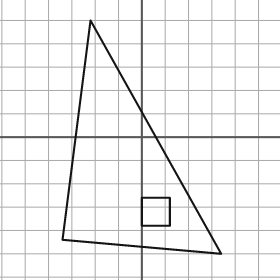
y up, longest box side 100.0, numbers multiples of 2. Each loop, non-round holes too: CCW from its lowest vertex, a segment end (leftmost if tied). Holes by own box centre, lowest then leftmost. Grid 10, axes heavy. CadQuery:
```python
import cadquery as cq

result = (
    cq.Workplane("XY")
    .moveTo(34.0, -50.0)
    .lineTo(-22.0, 50.0)
    .lineTo(-34.0, -44.0)
    .close()
    .moveTo(0.0, -38.0)
    .lineTo(12.0, -38.0)
    .lineTo(12.0, -26.0)
    .lineTo(0.0, -26.0)
    .close()
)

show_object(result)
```